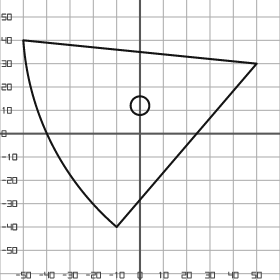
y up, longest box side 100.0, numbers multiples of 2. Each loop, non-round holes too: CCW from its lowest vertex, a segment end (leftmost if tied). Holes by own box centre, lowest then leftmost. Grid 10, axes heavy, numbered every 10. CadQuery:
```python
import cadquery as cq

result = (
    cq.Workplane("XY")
    .moveTo(-10.0, -40.0)
    .lineTo(50.0, 30.0)
    .lineTo(-50.0, 40.0)
    .threePointArc((-38.0, -4.0), (-10.0, -40.0))
    .close()
    .moveTo(0.0, 12.0)
    .circle(4.0)
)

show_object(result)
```